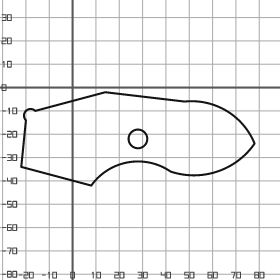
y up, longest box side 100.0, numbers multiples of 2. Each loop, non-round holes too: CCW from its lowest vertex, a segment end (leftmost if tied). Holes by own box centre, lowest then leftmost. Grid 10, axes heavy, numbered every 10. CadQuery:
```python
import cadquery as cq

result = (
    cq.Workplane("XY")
    .moveTo(8.0, -42.0)
    .threePointArc((24.0, -32.0), (42.0, -36.0))
    .threePointArc((62.0, -36.0), (78.0, -24.0))
    .threePointArc((66.0, -10.0), (48.0, -6.0))
    .lineTo(14.0, -2.0)
    .lineTo(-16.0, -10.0)
    .threePointArc((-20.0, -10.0), (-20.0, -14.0))
    .lineTo(-22.0, -34.0)
    .close()
    .moveTo(28.0, -22.0)
    .circle(4.0)
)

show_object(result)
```